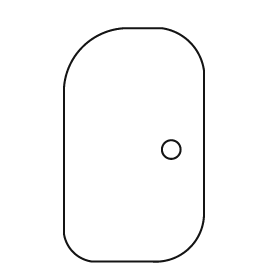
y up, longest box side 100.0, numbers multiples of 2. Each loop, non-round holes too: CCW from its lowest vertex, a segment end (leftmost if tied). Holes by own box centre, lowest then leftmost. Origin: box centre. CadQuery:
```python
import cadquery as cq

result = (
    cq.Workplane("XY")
    .moveTo(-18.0, -50.0)
    .lineTo(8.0, -50.0)
    .threePointArc((24.0, -44.0), (30.0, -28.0))
    .lineTo(30.0, 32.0)
    .threePointArc((24.0, 44.0), (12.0, 50.0))
    .lineTo(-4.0, 50.0)
    .threePointArc((-22.0, 42.0), (-30.0, 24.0))
    .lineTo(-30.0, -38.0)
    .threePointArc((-26.0, -46.0), (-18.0, -50.0))
    .close()
    .moveTo(16.0, -2.0)
    .circle(4.0)
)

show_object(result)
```